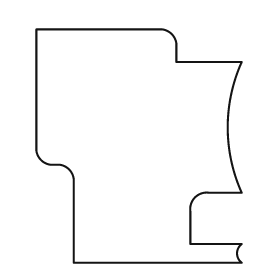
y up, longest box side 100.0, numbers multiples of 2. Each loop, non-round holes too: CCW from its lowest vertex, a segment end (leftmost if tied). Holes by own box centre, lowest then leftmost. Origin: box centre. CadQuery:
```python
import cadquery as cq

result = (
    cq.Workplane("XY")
    .moveTo(-28.0, -50.0)
    .lineTo(44.0, -50.0)
    .threePointArc((42.0, -46.0), (44.0, -42.0))
    .lineTo(22.0, -42.0)
    .lineTo(22.0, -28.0)
    .threePointArc((24.0, -22.0), (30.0, -20.0))
    .lineTo(44.0, -20.0)
    .threePointArc((38.0, 8.0), (44.0, 36.0))
    .lineTo(16.0, 36.0)
    .lineTo(16.0, 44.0)
    .threePointArc((14.0, 48.0), (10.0, 50.0))
    .lineTo(-44.0, 50.0)
    .lineTo(-44.0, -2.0)
    .threePointArc((-42.0, -6.0), (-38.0, -8.0))
    .lineTo(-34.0, -8.0)
    .threePointArc((-30.0, -10.0), (-28.0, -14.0))
    .close()
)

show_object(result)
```